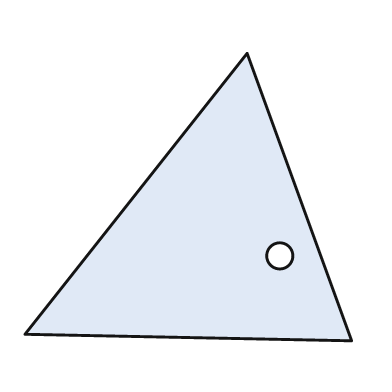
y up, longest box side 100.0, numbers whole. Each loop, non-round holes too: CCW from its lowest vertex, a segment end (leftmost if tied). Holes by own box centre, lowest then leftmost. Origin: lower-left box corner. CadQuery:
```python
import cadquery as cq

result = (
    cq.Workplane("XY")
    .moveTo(100.0, 0.0)
    .lineTo(68.0, 88.0)
    .lineTo(0.0, 2.0)
    .close()
    .moveTo(78.0, 26.0)
    .circle(4.0)
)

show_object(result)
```